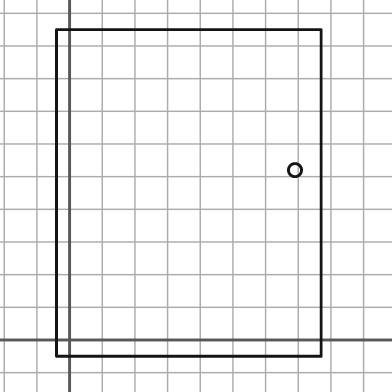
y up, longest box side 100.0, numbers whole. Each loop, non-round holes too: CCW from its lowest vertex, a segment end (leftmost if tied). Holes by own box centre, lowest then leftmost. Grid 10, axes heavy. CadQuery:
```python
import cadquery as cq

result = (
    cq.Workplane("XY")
    .moveTo(-4.0, -5.0)
    .lineTo(77.0, -5.0)
    .lineTo(77.0, 95.0)
    .lineTo(-4.0, 95.0)
    .close()
    .moveTo(69.0, 52.0)
    .circle(2.0)
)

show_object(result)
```